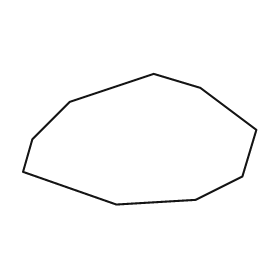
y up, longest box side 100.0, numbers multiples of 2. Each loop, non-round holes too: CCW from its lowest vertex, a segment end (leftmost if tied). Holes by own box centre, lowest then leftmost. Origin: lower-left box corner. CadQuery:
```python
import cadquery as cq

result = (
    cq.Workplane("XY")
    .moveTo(40.0, 0.0)
    .lineTo(74.0, 2.0)
    .lineTo(94.0, 12.0)
    .lineTo(100.0, 32.0)
    .lineTo(76.0, 50.0)
    .lineTo(56.0, 56.0)
    .lineTo(20.0, 44.0)
    .lineTo(4.0, 28.0)
    .lineTo(0.0, 14.0)
    .close()
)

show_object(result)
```